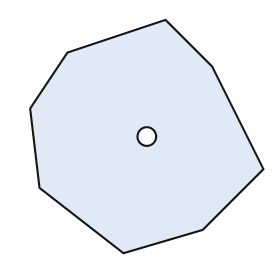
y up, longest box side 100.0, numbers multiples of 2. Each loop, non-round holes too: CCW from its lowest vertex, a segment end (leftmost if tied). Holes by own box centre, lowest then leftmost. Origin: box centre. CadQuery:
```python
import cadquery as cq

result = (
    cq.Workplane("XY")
    .moveTo(-10.0, -50.0)
    .lineTo(24.0, -40.0)
    .lineTo(50.0, -14.0)
    .lineTo(28.0, 30.0)
    .lineTo(8.0, 50.0)
    .lineTo(-34.0, 36.0)
    .lineTo(-50.0, 12.0)
    .lineTo(-46.0, -22.0)
    .close()
    .moveTo(0.0, 0.0)
    .circle(4.0)
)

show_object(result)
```